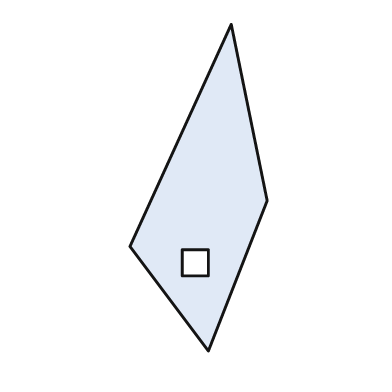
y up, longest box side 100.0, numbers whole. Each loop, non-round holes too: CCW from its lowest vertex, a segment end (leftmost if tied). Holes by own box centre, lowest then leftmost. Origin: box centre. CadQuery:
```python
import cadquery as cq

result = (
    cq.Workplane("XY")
    .moveTo(3.0, -50.0)
    .lineTo(21.0, -4.0)
    .lineTo(10.0, 50.0)
    .lineTo(-21.0, -18.0)
    .close()
    .moveTo(-5.0, -27.0)
    .lineTo(3.0, -27.0)
    .lineTo(3.0, -19.0)
    .lineTo(-5.0, -19.0)
    .close()
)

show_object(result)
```